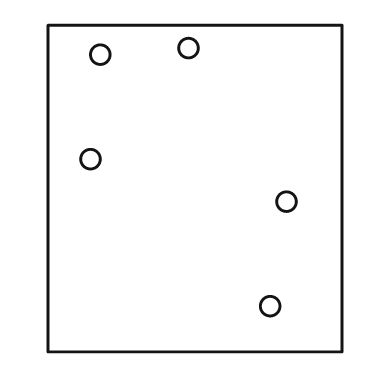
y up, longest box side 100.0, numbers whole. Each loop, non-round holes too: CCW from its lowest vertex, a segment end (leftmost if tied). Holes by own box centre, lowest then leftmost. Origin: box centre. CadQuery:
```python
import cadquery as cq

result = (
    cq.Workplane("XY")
    .moveTo(-45.0, -50.0)
    .lineTo(45.0, -50.0)
    .lineTo(45.0, 50.0)
    .lineTo(-45.0, 50.0)
    .close()
    .moveTo(23.0, -36.0)
    .circle(3.0)
    .moveTo(28.0, -4.0)
    .circle(3.0)
    .moveTo(-32.0, 9.0)
    .circle(3.0)
    .moveTo(-29.0, 41.0)
    .circle(3.0)
    .moveTo(-2.0, 43.0)
    .circle(3.0)
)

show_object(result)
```